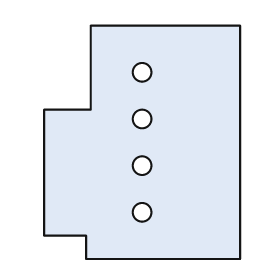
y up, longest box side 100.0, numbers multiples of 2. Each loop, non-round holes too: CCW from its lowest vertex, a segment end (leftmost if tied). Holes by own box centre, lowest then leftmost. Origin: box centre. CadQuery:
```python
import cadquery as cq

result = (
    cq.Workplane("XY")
    .moveTo(-24.0, -50.0)
    .lineTo(42.0, -50.0)
    .lineTo(42.0, 50.0)
    .lineTo(-22.0, 50.0)
    .lineTo(-22.0, 14.0)
    .lineTo(-42.0, 14.0)
    .lineTo(-42.0, -40.0)
    .lineTo(-24.0, -40.0)
    .close()
    .moveTo(0.0, -30.0)
    .circle(4.0)
    .moveTo(0.0, -10.0)
    .circle(4.0)
    .moveTo(0.0, 10.0)
    .circle(4.0)
    .moveTo(0.0, 30.0)
    .circle(4.0)
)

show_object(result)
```